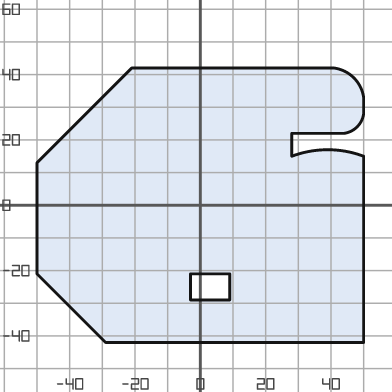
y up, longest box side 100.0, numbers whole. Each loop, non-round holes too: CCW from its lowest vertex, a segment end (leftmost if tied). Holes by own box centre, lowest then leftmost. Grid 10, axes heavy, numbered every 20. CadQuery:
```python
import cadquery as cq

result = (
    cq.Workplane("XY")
    .moveTo(-29.0, -42.0)
    .lineTo(50.0, -42.0)
    .lineTo(50.0, 15.0)
    .threePointArc((39.0, 17.0), (28.0, 15.0))
    .lineTo(28.0, 22.0)
    .lineTo(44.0, 22.0)
    .threePointArc((48.0, 24.0), (50.0, 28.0))
    .lineTo(50.0, 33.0)
    .threePointArc((47.0, 39.0), (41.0, 42.0))
    .lineTo(-21.0, 42.0)
    .lineTo(-50.0, 13.0)
    .lineTo(-50.0, -21.0)
    .close()
    .moveTo(-3.0, -29.0)
    .lineTo(9.0, -29.0)
    .lineTo(9.0, -21.0)
    .lineTo(-3.0, -21.0)
    .close()
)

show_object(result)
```